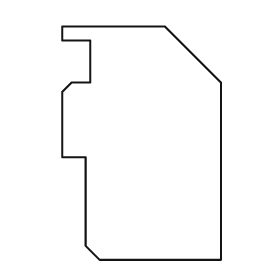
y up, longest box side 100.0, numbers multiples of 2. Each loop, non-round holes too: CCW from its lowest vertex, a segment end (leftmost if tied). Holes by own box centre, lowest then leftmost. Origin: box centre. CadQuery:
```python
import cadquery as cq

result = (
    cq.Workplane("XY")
    .moveTo(-18.0, -50.0)
    .lineTo(34.0, -50.0)
    .lineTo(34.0, 26.0)
    .lineTo(10.0, 50.0)
    .lineTo(-34.0, 50.0)
    .lineTo(-34.0, 44.0)
    .lineTo(-22.0, 44.0)
    .lineTo(-22.0, 26.0)
    .lineTo(-30.0, 26.0)
    .lineTo(-34.0, 22.0)
    .lineTo(-34.0, -6.0)
    .lineTo(-24.0, -6.0)
    .lineTo(-24.0, -44.0)
    .close()
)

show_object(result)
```